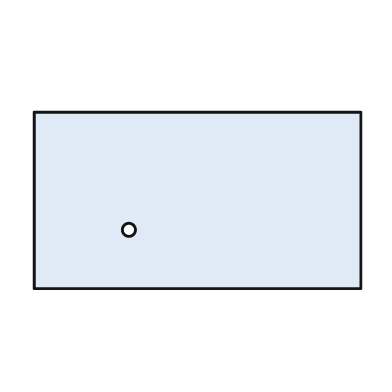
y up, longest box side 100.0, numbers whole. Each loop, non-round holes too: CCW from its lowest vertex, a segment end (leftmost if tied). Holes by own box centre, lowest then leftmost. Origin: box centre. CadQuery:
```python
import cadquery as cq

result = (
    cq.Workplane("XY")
    .moveTo(-50.0, -27.0)
    .lineTo(50.0, -27.0)
    .lineTo(50.0, 27.0)
    .lineTo(-50.0, 27.0)
    .close()
    .moveTo(-21.0, -9.0)
    .circle(2.0)
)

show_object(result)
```